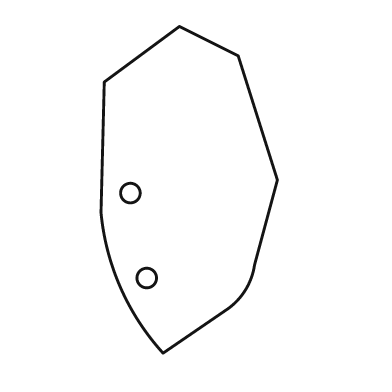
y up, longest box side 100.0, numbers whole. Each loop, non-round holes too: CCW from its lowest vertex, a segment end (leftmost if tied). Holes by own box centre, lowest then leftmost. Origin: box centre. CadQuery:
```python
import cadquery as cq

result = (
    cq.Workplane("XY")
    .moveTo(-8.0, -50.0)
    .lineTo(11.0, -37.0)
    .threePointArc((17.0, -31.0), (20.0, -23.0))
    .lineTo(27.0, 3.0)
    .lineTo(15.0, 41.0)
    .lineTo(-3.0, 50.0)
    .lineTo(-26.0, 33.0)
    .lineTo(-27.0, -7.0)
    .threePointArc((-21.0, -30.0), (-8.0, -50.0))
    .close()
    .moveTo(-13.0, -27.0)
    .circle(3.0)
    .moveTo(-18.0, -1.0)
    .circle(3.0)
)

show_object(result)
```